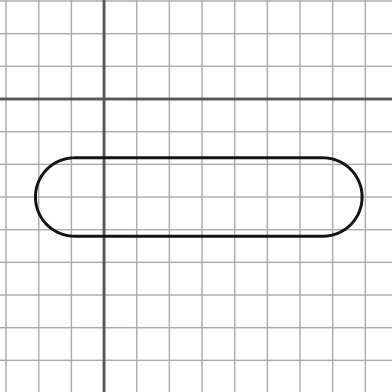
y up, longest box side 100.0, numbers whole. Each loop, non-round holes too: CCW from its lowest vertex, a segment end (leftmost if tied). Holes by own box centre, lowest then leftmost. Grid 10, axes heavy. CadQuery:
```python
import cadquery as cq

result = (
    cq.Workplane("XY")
    .moveTo(-9.0, -42.0)
    .lineTo(67.0, -42.0)
    .threePointArc((79.0, -30.0), (67.0, -18.0))
    .lineTo(-9.0, -18.0)
    .threePointArc((-21.0, -30.0), (-9.0, -42.0))
    .close()
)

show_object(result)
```